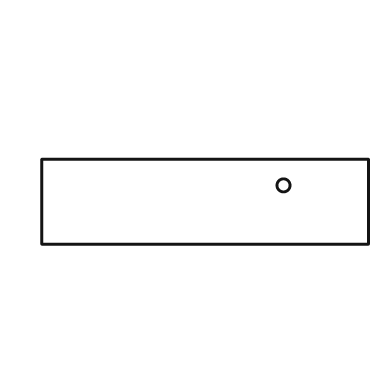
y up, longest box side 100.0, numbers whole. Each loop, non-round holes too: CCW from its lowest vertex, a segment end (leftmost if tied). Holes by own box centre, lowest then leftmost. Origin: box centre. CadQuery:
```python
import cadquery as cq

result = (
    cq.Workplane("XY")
    .moveTo(-50.0, -13.0)
    .lineTo(50.0, -13.0)
    .lineTo(50.0, 13.0)
    .lineTo(-50.0, 13.0)
    .close()
    .moveTo(24.0, 5.0)
    .circle(2.0)
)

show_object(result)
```